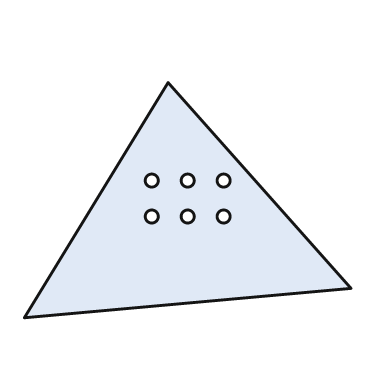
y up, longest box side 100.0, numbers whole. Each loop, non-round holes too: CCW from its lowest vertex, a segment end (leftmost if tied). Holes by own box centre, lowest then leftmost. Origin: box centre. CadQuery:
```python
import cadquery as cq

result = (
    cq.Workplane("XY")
    .moveTo(-50.0, -36.0)
    .lineTo(50.0, -27.0)
    .lineTo(-6.0, 36.0)
    .close()
    .moveTo(-11.0, -5.0)
    .circle(2.0)
    .moveTo(0.0, -5.0)
    .circle(2.0)
    .moveTo(11.0, -5.0)
    .circle(2.0)
    .moveTo(-11.0, 6.0)
    .circle(2.0)
    .moveTo(0.0, 6.0)
    .circle(2.0)
    .moveTo(11.0, 6.0)
    .circle(2.0)
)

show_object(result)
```